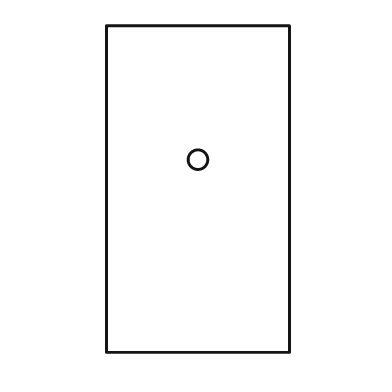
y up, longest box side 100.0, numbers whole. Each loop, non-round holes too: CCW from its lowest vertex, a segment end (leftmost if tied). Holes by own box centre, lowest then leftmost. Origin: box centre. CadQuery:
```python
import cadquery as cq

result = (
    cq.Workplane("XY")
    .moveTo(-28.0, -50.0)
    .lineTo(28.0, -50.0)
    .lineTo(28.0, 50.0)
    .lineTo(-28.0, 50.0)
    .close()
    .moveTo(0.0, 9.0)
    .circle(3.0)
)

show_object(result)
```